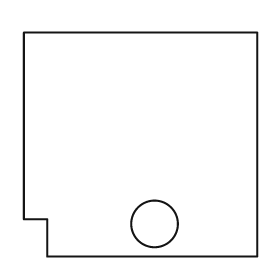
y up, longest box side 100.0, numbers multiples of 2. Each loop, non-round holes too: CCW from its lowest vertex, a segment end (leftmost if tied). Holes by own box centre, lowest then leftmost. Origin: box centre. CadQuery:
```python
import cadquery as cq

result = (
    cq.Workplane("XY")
    .moveTo(-40.0, -48.0)
    .lineTo(50.0, -48.0)
    .lineTo(50.0, 48.0)
    .lineTo(-50.0, 48.0)
    .lineTo(-50.0, -32.0)
    .lineTo(-40.0, -32.0)
    .close()
    .moveTo(6.0, -34.0)
    .circle(10.0)
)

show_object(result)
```